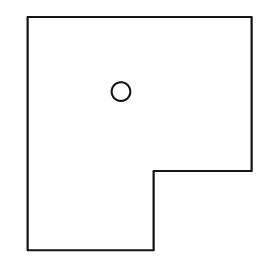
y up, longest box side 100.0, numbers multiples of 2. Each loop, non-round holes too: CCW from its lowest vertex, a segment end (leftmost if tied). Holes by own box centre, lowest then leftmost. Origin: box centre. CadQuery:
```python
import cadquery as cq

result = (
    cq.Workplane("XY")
    .moveTo(-48.0, -50.0)
    .lineTo(6.0, -50.0)
    .lineTo(6.0, -16.0)
    .lineTo(48.0, -16.0)
    .lineTo(48.0, 50.0)
    .lineTo(-48.0, 50.0)
    .close()
    .moveTo(-8.0, 18.0)
    .circle(4.0)
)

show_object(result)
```